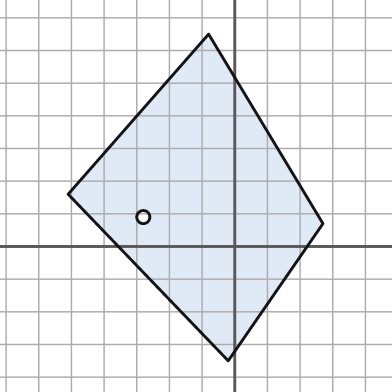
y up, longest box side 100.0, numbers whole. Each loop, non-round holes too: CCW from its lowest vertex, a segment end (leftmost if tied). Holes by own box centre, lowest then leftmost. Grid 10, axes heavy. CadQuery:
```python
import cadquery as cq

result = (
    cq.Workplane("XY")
    .moveTo(-2.0, -35.0)
    .lineTo(27.0, 7.0)
    .lineTo(-8.0, 65.0)
    .lineTo(-51.0, 16.0)
    .close()
    .moveTo(-28.0, 9.0)
    .circle(2.0)
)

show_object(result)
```